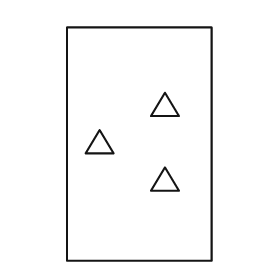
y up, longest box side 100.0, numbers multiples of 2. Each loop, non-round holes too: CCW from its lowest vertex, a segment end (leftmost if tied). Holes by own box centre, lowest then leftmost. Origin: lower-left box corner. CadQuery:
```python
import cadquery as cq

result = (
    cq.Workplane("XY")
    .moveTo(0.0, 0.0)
    .lineTo(62.0, 0.0)
    .lineTo(62.0, 100.0)
    .lineTo(0.0, 100.0)
    .close()
    .moveTo(36.0, 30.0)
    .lineTo(48.0, 30.0)
    .lineTo(42.0, 40.0)
    .close()
    .moveTo(8.0, 46.0)
    .lineTo(20.0, 46.0)
    .lineTo(14.0, 56.0)
    .close()
    .moveTo(36.0, 62.0)
    .lineTo(48.0, 62.0)
    .lineTo(42.0, 72.0)
    .close()
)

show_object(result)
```